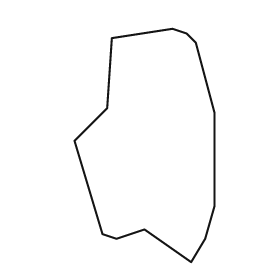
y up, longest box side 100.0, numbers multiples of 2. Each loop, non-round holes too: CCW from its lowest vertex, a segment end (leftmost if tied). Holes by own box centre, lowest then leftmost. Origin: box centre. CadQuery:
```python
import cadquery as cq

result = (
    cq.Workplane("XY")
    .moveTo(20.0, -50.0)
    .lineTo(26.0, -40.0)
    .lineTo(30.0, -26.0)
    .lineTo(30.0, 14.0)
    .lineTo(22.0, 44.0)
    .lineTo(18.0, 48.0)
    .lineTo(12.0, 50.0)
    .lineTo(-14.0, 46.0)
    .lineTo(-16.0, 16.0)
    .lineTo(-30.0, 2.0)
    .lineTo(-18.0, -38.0)
    .lineTo(-12.0, -40.0)
    .lineTo(0.0, -36.0)
    .close()
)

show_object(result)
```